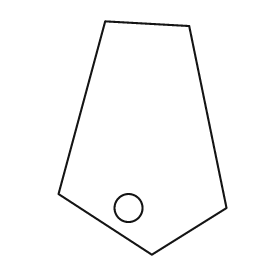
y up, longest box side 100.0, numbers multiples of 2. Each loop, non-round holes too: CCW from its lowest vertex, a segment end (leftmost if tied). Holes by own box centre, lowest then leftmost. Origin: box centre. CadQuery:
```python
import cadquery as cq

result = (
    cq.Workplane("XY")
    .moveTo(4.0, -50.0)
    .lineTo(36.0, -30.0)
    .lineTo(20.0, 48.0)
    .lineTo(-16.0, 50.0)
    .lineTo(-36.0, -24.0)
    .close()
    .moveTo(-6.0, -30.0)
    .circle(6.0)
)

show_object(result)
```